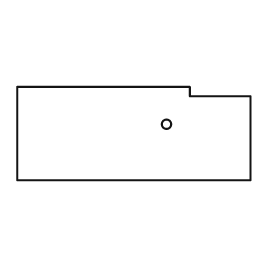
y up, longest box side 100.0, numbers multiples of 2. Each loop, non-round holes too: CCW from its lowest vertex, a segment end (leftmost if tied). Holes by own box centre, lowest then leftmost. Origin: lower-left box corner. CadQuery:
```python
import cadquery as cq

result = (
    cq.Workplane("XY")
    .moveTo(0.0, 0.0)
    .lineTo(100.0, 0.0)
    .lineTo(100.0, 36.0)
    .lineTo(74.0, 36.0)
    .lineTo(74.0, 40.0)
    .lineTo(0.0, 40.0)
    .close()
    .moveTo(64.0, 24.0)
    .circle(2.0)
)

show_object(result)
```